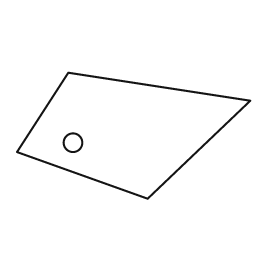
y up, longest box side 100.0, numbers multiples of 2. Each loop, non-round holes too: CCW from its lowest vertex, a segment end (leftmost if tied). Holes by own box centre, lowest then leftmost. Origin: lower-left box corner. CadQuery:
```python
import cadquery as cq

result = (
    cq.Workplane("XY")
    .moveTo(56.0, 0.0)
    .lineTo(100.0, 42.0)
    .lineTo(22.0, 54.0)
    .lineTo(0.0, 20.0)
    .close()
    .moveTo(24.0, 24.0)
    .circle(4.0)
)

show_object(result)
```